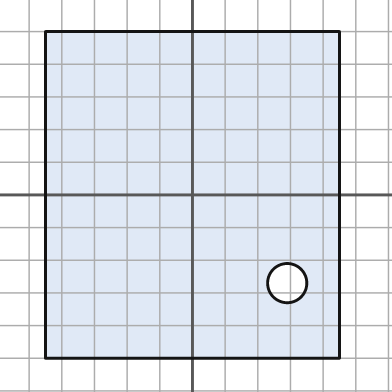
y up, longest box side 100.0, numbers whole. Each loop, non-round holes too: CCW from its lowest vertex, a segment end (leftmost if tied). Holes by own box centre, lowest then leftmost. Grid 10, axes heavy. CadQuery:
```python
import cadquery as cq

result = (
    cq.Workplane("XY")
    .moveTo(-45.0, -50.0)
    .lineTo(45.0, -50.0)
    .lineTo(45.0, 50.0)
    .lineTo(-45.0, 50.0)
    .close()
    .moveTo(29.0, -27.0)
    .circle(6.0)
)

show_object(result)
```